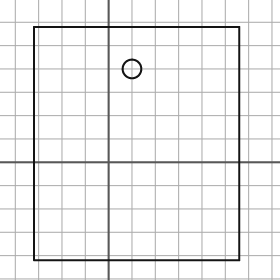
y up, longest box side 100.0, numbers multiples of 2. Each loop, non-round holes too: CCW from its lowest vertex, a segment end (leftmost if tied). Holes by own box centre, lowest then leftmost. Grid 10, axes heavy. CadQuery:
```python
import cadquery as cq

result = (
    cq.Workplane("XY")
    .moveTo(-32.0, -42.0)
    .lineTo(56.0, -42.0)
    .lineTo(56.0, 58.0)
    .lineTo(-32.0, 58.0)
    .close()
    .moveTo(10.0, 40.0)
    .circle(4.0)
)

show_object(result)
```